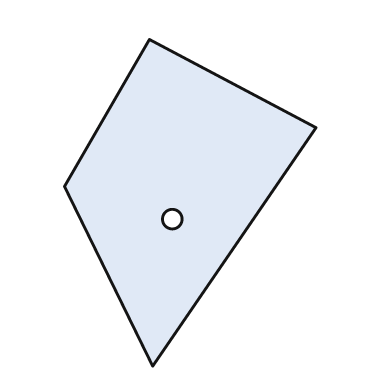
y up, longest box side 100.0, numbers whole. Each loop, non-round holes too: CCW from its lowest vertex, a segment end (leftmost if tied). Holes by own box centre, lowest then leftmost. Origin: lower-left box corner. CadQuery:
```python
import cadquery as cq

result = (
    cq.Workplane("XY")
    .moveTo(27.0, 0.0)
    .lineTo(77.0, 73.0)
    .lineTo(26.0, 100.0)
    .lineTo(0.0, 55.0)
    .close()
    .moveTo(33.0, 45.0)
    .circle(3.0)
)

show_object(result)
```